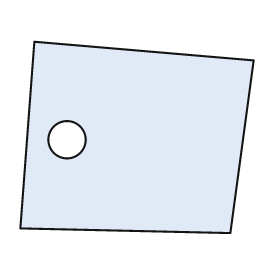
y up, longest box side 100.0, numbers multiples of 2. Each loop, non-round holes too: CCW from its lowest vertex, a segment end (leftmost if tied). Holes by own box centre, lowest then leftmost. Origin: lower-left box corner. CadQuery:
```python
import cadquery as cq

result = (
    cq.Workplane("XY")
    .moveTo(90.0, 0.0)
    .lineTo(100.0, 74.0)
    .lineTo(6.0, 82.0)
    .lineTo(0.0, 2.0)
    .close()
    .moveTo(20.0, 40.0)
    .circle(8.0)
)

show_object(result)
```